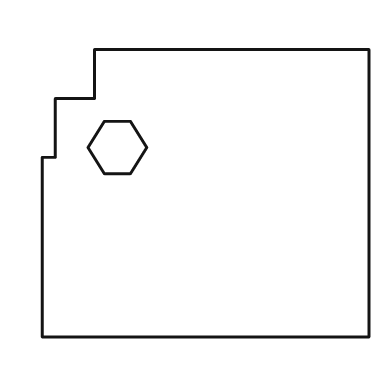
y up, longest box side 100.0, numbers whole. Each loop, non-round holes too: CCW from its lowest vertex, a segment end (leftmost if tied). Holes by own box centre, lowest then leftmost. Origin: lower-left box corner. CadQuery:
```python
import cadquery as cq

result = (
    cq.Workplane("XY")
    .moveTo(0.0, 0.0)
    .lineTo(100.0, 0.0)
    .lineTo(100.0, 88.0)
    .lineTo(16.0, 88.0)
    .lineTo(16.0, 73.0)
    .lineTo(4.0, 73.0)
    .lineTo(4.0, 55.0)
    .lineTo(0.0, 55.0)
    .close()
    .moveTo(19.0, 50.0)
    .lineTo(27.0, 50.0)
    .lineTo(32.0, 58.0)
    .lineTo(27.0, 66.0)
    .lineTo(19.0, 66.0)
    .lineTo(14.0, 58.0)
    .close()
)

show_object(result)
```